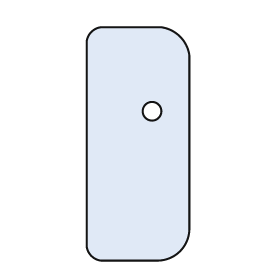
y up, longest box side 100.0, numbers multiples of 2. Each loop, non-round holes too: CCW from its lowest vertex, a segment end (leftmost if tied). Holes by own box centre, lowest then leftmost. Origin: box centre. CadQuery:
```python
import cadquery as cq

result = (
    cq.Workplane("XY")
    .moveTo(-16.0, -50.0)
    .lineTo(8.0, -50.0)
    .threePointArc((18.0, -46.0), (22.0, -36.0))
    .lineTo(22.0, 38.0)
    .threePointArc((18.0, 46.0), (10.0, 50.0))
    .lineTo(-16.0, 50.0)
    .threePointArc((-20.0, 48.0), (-22.0, 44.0))
    .lineTo(-22.0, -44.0)
    .threePointArc((-20.0, -48.0), (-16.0, -50.0))
    .close()
    .moveTo(6.0, 14.0)
    .circle(4.0)
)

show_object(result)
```